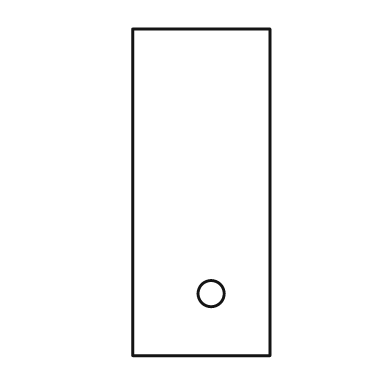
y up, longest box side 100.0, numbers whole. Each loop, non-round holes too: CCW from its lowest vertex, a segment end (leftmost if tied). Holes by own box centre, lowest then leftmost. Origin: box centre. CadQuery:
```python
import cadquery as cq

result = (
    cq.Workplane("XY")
    .moveTo(-21.0, -50.0)
    .lineTo(21.0, -50.0)
    .lineTo(21.0, 50.0)
    .lineTo(-21.0, 50.0)
    .close()
    .moveTo(3.0, -31.0)
    .circle(4.0)
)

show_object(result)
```